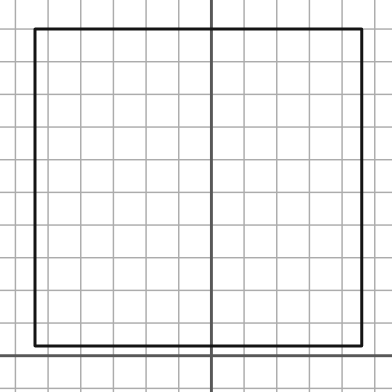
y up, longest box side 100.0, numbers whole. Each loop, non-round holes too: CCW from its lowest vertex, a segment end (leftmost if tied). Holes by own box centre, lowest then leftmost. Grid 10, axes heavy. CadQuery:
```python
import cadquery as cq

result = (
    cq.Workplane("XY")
    .moveTo(-54.0, 3.0)
    .lineTo(46.0, 3.0)
    .lineTo(46.0, 100.0)
    .lineTo(-54.0, 100.0)
    .close()
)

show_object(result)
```